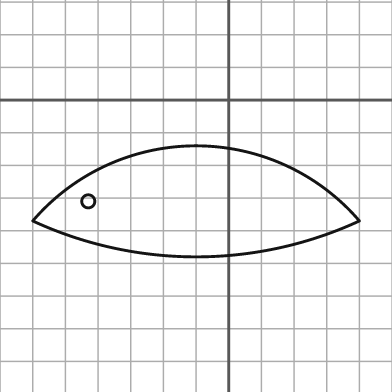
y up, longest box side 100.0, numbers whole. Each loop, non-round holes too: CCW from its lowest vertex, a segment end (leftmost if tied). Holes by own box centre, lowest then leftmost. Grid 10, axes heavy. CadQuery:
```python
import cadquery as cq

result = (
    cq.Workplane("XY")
    .moveTo(-60.0, -37.0)
    .threePointArc((-10.0, -48.0), (40.0, -37.0))
    .threePointArc((-10.0, -14.0), (-60.0, -37.0))
    .close()
    .moveTo(-43.0, -31.0)
    .circle(2.0)
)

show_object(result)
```